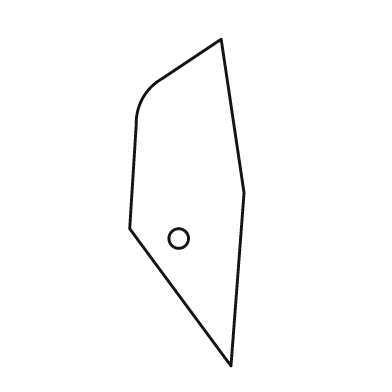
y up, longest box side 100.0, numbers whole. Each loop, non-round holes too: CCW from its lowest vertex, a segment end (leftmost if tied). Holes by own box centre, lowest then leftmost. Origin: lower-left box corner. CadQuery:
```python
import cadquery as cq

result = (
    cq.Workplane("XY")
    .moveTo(31.0, 0.0)
    .lineTo(35.0, 53.0)
    .lineTo(28.0, 100.0)
    .lineTo(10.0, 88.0)
    .threePointArc((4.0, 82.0), (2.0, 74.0))
    .lineTo(0.0, 42.0)
    .close()
    .moveTo(15.0, 39.0)
    .circle(3.0)
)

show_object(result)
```